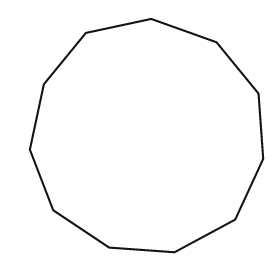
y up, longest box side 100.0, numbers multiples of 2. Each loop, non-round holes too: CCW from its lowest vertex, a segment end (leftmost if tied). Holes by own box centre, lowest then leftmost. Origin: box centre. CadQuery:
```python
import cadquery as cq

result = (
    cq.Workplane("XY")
    .moveTo(12.0, -50.0)
    .lineTo(38.0, -36.0)
    .lineTo(50.0, -10.0)
    .lineTo(48.0, 18.0)
    .lineTo(30.0, 40.0)
    .lineTo(2.0, 50.0)
    .lineTo(-26.0, 44.0)
    .lineTo(-44.0, 22.0)
    .lineTo(-50.0, -6.0)
    .lineTo(-40.0, -32.0)
    .lineTo(-16.0, -48.0)
    .close()
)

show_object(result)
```